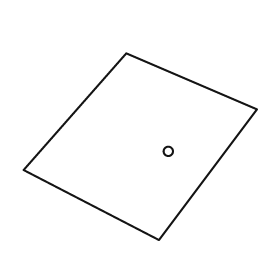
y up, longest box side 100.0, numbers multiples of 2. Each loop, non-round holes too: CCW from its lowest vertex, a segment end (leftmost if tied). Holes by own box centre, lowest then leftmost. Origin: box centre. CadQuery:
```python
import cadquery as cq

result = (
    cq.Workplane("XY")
    .moveTo(8.0, -40.0)
    .lineTo(50.0, 16.0)
    .lineTo(-6.0, 40.0)
    .lineTo(-50.0, -10.0)
    .close()
    .moveTo(12.0, -2.0)
    .circle(2.0)
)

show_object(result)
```